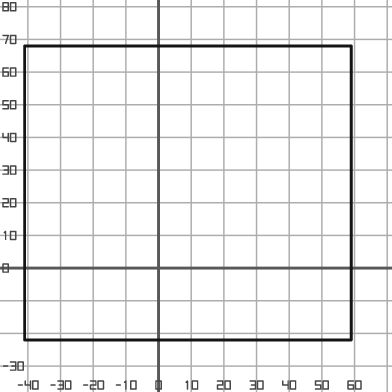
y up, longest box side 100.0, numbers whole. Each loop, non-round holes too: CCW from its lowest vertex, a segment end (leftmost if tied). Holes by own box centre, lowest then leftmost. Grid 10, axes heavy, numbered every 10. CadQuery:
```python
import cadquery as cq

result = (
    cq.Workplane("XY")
    .moveTo(-41.0, -22.0)
    .lineTo(59.0, -22.0)
    .lineTo(59.0, 68.0)
    .lineTo(-41.0, 68.0)
    .close()
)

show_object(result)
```